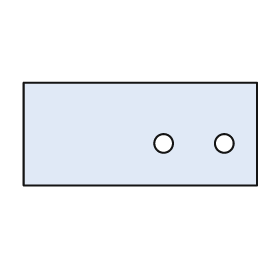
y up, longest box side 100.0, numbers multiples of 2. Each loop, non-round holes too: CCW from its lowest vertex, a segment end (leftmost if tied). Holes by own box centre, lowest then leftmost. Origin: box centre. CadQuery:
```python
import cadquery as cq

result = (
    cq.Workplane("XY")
    .moveTo(-50.0, -22.0)
    .lineTo(50.0, -22.0)
    .lineTo(50.0, 22.0)
    .lineTo(-50.0, 22.0)
    .close()
    .moveTo(10.0, -4.0)
    .circle(4.0)
    .moveTo(36.0, -4.0)
    .circle(4.0)
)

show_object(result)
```